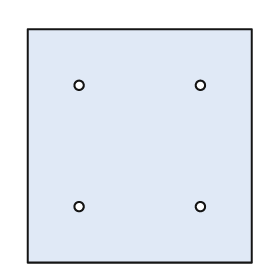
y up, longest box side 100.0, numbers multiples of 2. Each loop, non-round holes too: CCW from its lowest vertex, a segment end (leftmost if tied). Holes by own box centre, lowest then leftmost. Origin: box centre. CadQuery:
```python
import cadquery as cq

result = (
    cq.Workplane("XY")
    .moveTo(-48.0, -50.0)
    .lineTo(48.0, -50.0)
    .lineTo(48.0, 50.0)
    .lineTo(-48.0, 50.0)
    .close()
    .moveTo(-26.0, -26.0)
    .circle(2.0)
    .moveTo(26.0, -26.0)
    .circle(2.0)
    .moveTo(-26.0, 26.0)
    .circle(2.0)
    .moveTo(26.0, 26.0)
    .circle(2.0)
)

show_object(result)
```